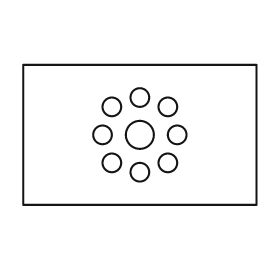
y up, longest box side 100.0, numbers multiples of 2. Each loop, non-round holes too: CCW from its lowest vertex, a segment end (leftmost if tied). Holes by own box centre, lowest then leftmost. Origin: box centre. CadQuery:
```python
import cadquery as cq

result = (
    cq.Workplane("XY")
    .moveTo(-50.0, -30.0)
    .lineTo(50.0, -30.0)
    .lineTo(50.0, 30.0)
    .lineTo(-50.0, 30.0)
    .close()
    .moveTo(0.0, -16.0)
    .circle(4.0)
    .moveTo(-12.0, -12.0)
    .circle(4.0)
    .moveTo(12.0, -12.0)
    .circle(4.0)
    .moveTo(-16.0, 0.0)
    .circle(4.0)
    .moveTo(0.0, 0.0)
    .circle(6.0)
    .moveTo(16.0, 0.0)
    .circle(4.0)
    .moveTo(-12.0, 12.0)
    .circle(4.0)
    .moveTo(12.0, 12.0)
    .circle(4.0)
    .moveTo(0.0, 16.0)
    .circle(4.0)
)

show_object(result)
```